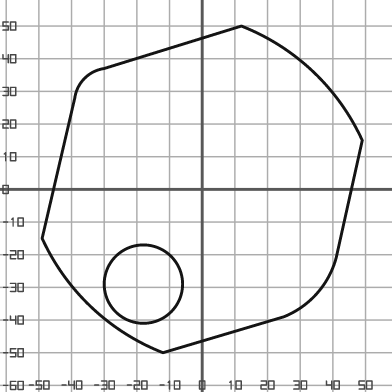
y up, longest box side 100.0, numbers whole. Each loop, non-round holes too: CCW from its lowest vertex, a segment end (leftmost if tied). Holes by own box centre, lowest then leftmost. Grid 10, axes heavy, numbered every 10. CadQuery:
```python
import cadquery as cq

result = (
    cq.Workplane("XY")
    .moveTo(-12.0, -50.0)
    .lineTo(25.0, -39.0)
    .threePointArc((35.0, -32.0), (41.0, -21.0))
    .lineTo(49.0, 15.0)
    .threePointArc((34.0, 36.0), (12.0, 50.0))
    .lineTo(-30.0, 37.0)
    .threePointArc((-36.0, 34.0), (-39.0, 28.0))
    .lineTo(-49.0, -15.0)
    .threePointArc((-34.0, -36.0), (-12.0, -50.0))
    .close()
    .moveTo(-18.0, -29.0)
    .circle(12.0)
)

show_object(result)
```